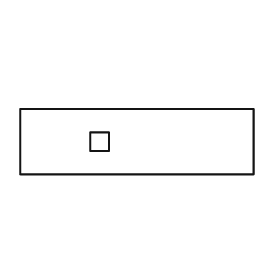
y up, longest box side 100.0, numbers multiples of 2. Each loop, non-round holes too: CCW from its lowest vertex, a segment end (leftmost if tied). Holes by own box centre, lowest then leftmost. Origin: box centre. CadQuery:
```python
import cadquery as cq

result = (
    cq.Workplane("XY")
    .moveTo(-50.0, -14.0)
    .lineTo(50.0, -14.0)
    .lineTo(50.0, 14.0)
    .lineTo(-50.0, 14.0)
    .close()
    .moveTo(-20.0, -4.0)
    .lineTo(-12.0, -4.0)
    .lineTo(-12.0, 4.0)
    .lineTo(-20.0, 4.0)
    .close()
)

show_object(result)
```